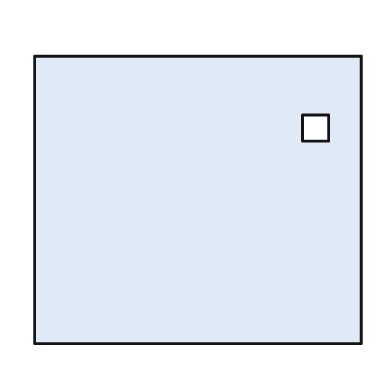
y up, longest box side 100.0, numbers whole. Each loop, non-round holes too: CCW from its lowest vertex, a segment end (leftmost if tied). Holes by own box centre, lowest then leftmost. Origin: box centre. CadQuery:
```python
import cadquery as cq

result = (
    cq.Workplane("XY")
    .moveTo(-50.0, -44.0)
    .lineTo(50.0, -44.0)
    .lineTo(50.0, 44.0)
    .lineTo(-50.0, 44.0)
    .close()
    .moveTo(32.0, 18.0)
    .lineTo(40.0, 18.0)
    .lineTo(40.0, 26.0)
    .lineTo(32.0, 26.0)
    .close()
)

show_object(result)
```